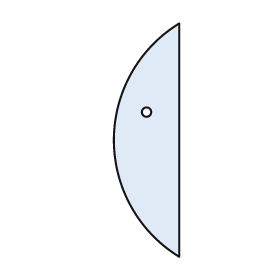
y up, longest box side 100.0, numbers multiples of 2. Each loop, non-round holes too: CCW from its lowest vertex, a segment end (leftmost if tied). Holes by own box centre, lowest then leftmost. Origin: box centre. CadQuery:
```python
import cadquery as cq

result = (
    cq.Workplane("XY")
    .moveTo(14.0, -50.0)
    .lineTo(14.0, 50.0)
    .threePointArc((-14.0, 0.0), (14.0, -50.0))
    .close()
    .moveTo(0.0, 12.0)
    .circle(2.0)
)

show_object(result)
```